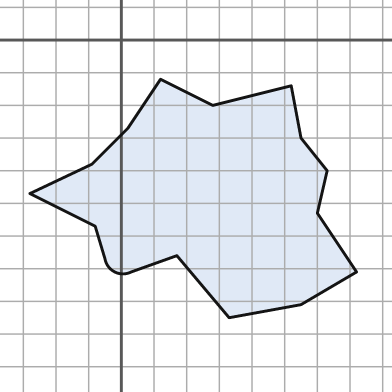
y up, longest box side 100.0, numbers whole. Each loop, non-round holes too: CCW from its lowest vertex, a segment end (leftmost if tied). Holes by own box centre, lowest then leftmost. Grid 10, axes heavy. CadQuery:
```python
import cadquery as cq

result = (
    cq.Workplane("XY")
    .moveTo(33.0, -85.0)
    .lineTo(55.0, -81.0)
    .lineTo(72.0, -71.0)
    .lineTo(60.0, -53.0)
    .lineTo(63.0, -40.0)
    .lineTo(55.0, -30.0)
    .lineTo(52.0, -14.0)
    .lineTo(28.0, -20.0)
    .lineTo(12.0, -12.0)
    .lineTo(2.0, -27.0)
    .lineTo(-9.0, -38.0)
    .lineTo(-28.0, -47.0)
    .lineTo(-8.0, -57.0)
    .lineTo(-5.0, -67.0)
    .threePointArc((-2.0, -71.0), (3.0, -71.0))
    .lineTo(17.0, -66.0)
    .close()
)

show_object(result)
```